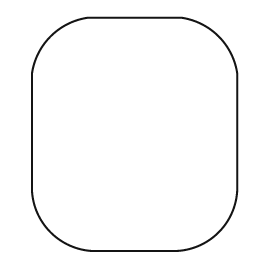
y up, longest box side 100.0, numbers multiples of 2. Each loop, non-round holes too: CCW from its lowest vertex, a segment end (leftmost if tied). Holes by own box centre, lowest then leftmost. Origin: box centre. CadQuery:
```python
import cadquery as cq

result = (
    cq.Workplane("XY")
    .moveTo(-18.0, -50.0)
    .lineTo(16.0, -50.0)
    .threePointArc((36.0, -42.0), (44.0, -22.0))
    .lineTo(44.0, 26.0)
    .threePointArc((36.0, 42.0), (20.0, 50.0))
    .lineTo(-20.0, 50.0)
    .threePointArc((-36.0, 42.0), (-44.0, 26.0))
    .lineTo(-44.0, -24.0)
    .threePointArc((-36.0, -42.0), (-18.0, -50.0))
    .close()
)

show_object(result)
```